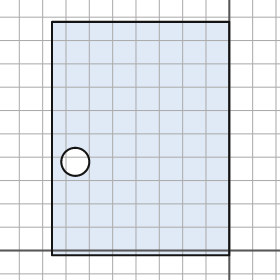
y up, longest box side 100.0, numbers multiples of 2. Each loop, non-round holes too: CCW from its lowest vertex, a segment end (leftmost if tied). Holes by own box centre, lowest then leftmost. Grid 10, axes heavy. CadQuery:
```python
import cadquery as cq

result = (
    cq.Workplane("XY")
    .moveTo(-76.0, -2.0)
    .lineTo(0.0, -2.0)
    .lineTo(0.0, 98.0)
    .lineTo(-76.0, 98.0)
    .close()
    .moveTo(-66.0, 38.0)
    .circle(6.0)
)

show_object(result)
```